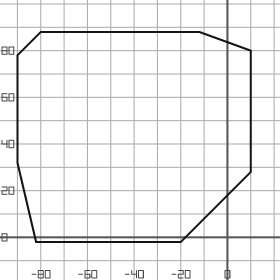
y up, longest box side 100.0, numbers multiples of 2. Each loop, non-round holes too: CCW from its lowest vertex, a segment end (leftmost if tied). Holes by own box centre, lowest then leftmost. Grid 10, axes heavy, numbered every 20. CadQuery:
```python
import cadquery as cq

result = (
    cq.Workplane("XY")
    .moveTo(-82.0, -2.0)
    .lineTo(-20.0, -2.0)
    .lineTo(10.0, 28.0)
    .lineTo(10.0, 80.0)
    .lineTo(-12.0, 88.0)
    .lineTo(-80.0, 88.0)
    .lineTo(-90.0, 78.0)
    .lineTo(-90.0, 32.0)
    .close()
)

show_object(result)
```